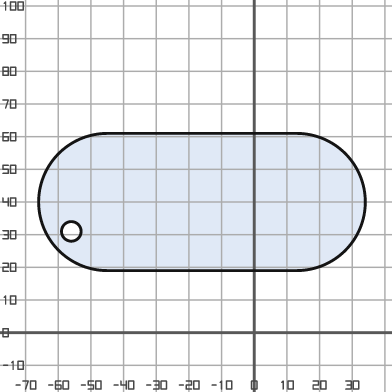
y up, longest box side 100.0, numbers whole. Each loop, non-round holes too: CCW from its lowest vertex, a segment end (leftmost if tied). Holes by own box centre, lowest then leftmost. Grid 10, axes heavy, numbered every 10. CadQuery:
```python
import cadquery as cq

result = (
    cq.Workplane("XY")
    .moveTo(-45.0, 19.0)
    .lineTo(13.0, 19.0)
    .threePointArc((34.0, 40.0), (13.0, 61.0))
    .lineTo(-45.0, 61.0)
    .threePointArc((-66.0, 40.0), (-45.0, 19.0))
    .close()
    .moveTo(-56.0, 31.0)
    .circle(3.0)
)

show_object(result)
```